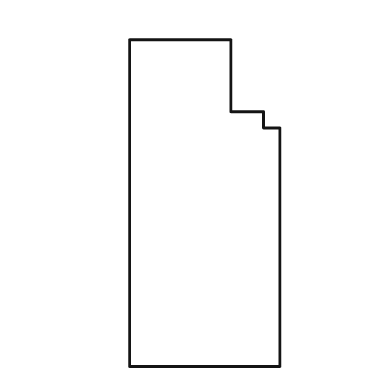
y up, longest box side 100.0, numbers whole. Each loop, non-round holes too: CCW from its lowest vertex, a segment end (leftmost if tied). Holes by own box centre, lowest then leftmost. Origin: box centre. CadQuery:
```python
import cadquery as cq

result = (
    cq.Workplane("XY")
    .moveTo(-23.0, -50.0)
    .lineTo(23.0, -50.0)
    .lineTo(23.0, 23.0)
    .lineTo(18.0, 23.0)
    .lineTo(18.0, 28.0)
    .lineTo(8.0, 28.0)
    .lineTo(8.0, 50.0)
    .lineTo(-23.0, 50.0)
    .close()
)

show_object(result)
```